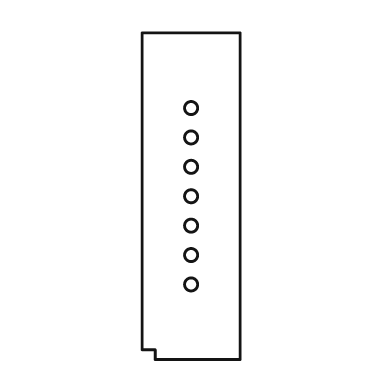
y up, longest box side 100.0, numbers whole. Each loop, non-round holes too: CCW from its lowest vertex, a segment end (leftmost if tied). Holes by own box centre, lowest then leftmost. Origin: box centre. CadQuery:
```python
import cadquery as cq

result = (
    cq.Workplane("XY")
    .moveTo(-11.0, -50.0)
    .lineTo(15.0, -50.0)
    .lineTo(15.0, 50.0)
    .lineTo(-15.0, 50.0)
    .lineTo(-15.0, -47.0)
    .lineTo(-11.0, -47.0)
    .close()
    .moveTo(0.0, -27.0)
    .circle(2.0)
    .moveTo(0.0, -18.0)
    .circle(2.0)
    .moveTo(0.0, -9.0)
    .circle(2.0)
    .moveTo(0.0, 0.0)
    .circle(2.0)
    .moveTo(0.0, 9.0)
    .circle(2.0)
    .moveTo(0.0, 18.0)
    .circle(2.0)
    .moveTo(0.0, 27.0)
    .circle(2.0)
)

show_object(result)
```